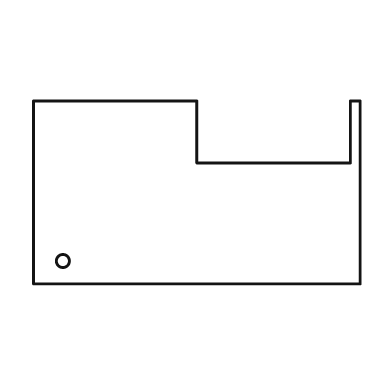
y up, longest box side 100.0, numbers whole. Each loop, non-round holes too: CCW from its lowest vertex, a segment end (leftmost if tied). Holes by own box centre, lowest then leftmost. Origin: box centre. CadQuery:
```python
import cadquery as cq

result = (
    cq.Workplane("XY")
    .moveTo(-50.0, -28.0)
    .lineTo(50.0, -28.0)
    .lineTo(50.0, 28.0)
    .lineTo(47.0, 28.0)
    .lineTo(47.0, 9.0)
    .lineTo(0.0, 9.0)
    .lineTo(0.0, 28.0)
    .lineTo(-50.0, 28.0)
    .close()
    .moveTo(-41.0, -21.0)
    .circle(2.0)
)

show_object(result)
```